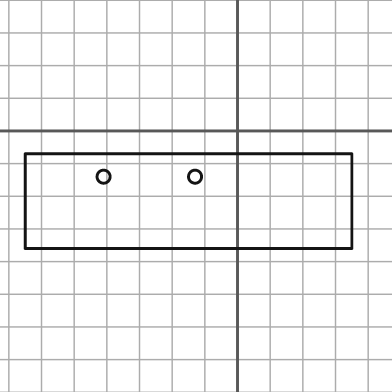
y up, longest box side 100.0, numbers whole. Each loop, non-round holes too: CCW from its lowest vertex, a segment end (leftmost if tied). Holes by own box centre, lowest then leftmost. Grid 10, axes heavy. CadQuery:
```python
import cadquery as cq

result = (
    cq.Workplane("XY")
    .moveTo(-65.0, -36.0)
    .lineTo(35.0, -36.0)
    .lineTo(35.0, -7.0)
    .lineTo(-65.0, -7.0)
    .close()
    .moveTo(-41.0, -14.0)
    .circle(2.0)
    .moveTo(-13.0, -14.0)
    .circle(2.0)
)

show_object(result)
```